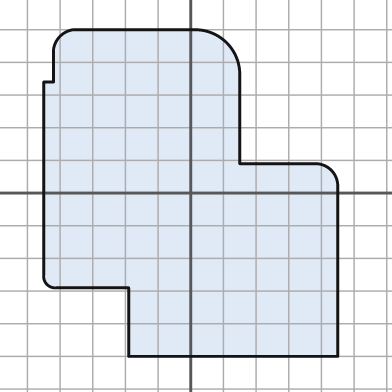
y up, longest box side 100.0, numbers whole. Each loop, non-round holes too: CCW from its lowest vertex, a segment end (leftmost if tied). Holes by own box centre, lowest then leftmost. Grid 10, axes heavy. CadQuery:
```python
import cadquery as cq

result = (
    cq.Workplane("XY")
    .moveTo(-19.0, -50.0)
    .lineTo(45.0, -50.0)
    .lineTo(45.0, 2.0)
    .threePointArc((43.0, 7.0), (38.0, 9.0))
    .lineTo(15.0, 9.0)
    .lineTo(15.0, 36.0)
    .threePointArc((11.0, 46.0), (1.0, 50.0))
    .lineTo(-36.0, 50.0)
    .threePointArc((-40.0, 48.0), (-42.0, 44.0))
    .lineTo(-42.0, 34.0)
    .lineTo(-45.0, 34.0)
    .lineTo(-45.0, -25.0)
    .threePointArc((-44.0, -28.0), (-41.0, -29.0))
    .lineTo(-19.0, -29.0)
    .close()
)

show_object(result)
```